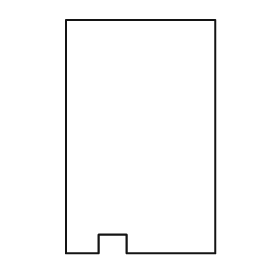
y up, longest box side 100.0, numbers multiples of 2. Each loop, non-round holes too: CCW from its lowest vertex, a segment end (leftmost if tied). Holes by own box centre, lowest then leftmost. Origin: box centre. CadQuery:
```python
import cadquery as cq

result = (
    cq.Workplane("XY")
    .moveTo(-32.0, -50.0)
    .lineTo(-18.0, -50.0)
    .lineTo(-18.0, -42.0)
    .lineTo(-6.0, -42.0)
    .lineTo(-6.0, -50.0)
    .lineTo(32.0, -50.0)
    .lineTo(32.0, 50.0)
    .lineTo(-32.0, 50.0)
    .close()
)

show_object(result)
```